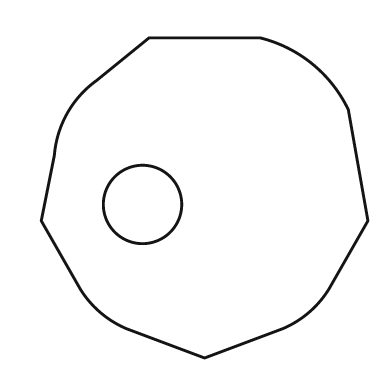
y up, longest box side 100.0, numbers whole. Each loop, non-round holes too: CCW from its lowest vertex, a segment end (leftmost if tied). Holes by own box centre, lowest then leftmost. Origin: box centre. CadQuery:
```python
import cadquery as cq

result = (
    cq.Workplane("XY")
    .moveTo(0.0, -49.0)
    .lineTo(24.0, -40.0)
    .threePointArc((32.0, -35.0), (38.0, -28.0))
    .lineTo(50.0, -7.0)
    .lineTo(44.0, 27.0)
    .threePointArc((33.0, 41.0), (17.0, 49.0))
    .lineTo(-17.0, 49.0)
    .lineTo(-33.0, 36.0)
    .threePointArc((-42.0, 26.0), (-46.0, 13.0))
    .lineTo(-50.0, -7.0)
    .lineTo(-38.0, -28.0)
    .threePointArc((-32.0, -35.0), (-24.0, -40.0))
    .close()
    .moveTo(-19.0, -2.0)
    .circle(12.0)
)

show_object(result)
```